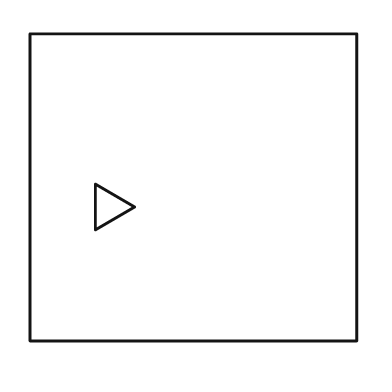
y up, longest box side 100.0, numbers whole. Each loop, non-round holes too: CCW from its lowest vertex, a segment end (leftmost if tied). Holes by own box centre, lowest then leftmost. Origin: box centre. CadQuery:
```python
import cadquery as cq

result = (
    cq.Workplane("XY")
    .moveTo(-50.0, -47.0)
    .lineTo(50.0, -47.0)
    .lineTo(50.0, 47.0)
    .lineTo(-50.0, 47.0)
    .close()
    .moveTo(-30.0, -13.0)
    .lineTo(-18.0, -6.0)
    .lineTo(-30.0, 1.0)
    .close()
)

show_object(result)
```